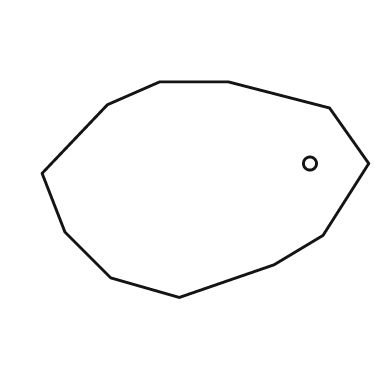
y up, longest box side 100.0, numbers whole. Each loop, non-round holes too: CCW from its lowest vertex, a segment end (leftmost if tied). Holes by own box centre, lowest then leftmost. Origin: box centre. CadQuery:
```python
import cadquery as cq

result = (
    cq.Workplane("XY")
    .moveTo(-8.0, -33.0)
    .lineTo(21.0, -23.0)
    .lineTo(36.0, -14.0)
    .lineTo(50.0, 8.0)
    .lineTo(38.0, 25.0)
    .lineTo(7.0, 33.0)
    .lineTo(-14.0, 33.0)
    .lineTo(-30.0, 26.0)
    .lineTo(-50.0, 5.0)
    .lineTo(-43.0, -13.0)
    .lineTo(-29.0, -27.0)
    .close()
    .moveTo(32.0, 8.0)
    .circle(2.0)
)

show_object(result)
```